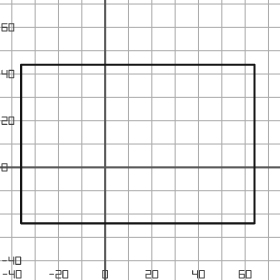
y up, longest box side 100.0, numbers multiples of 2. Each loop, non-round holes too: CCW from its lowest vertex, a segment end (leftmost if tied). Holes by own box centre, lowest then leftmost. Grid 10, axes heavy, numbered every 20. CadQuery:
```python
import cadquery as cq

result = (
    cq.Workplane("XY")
    .moveTo(-36.0, -24.0)
    .lineTo(64.0, -24.0)
    .lineTo(64.0, 44.0)
    .lineTo(-36.0, 44.0)
    .close()
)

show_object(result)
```